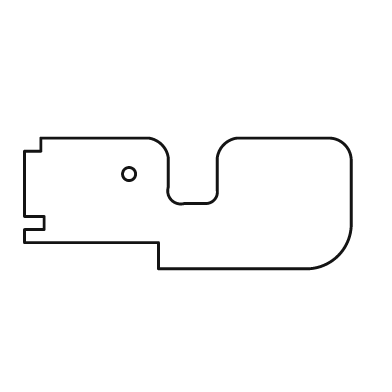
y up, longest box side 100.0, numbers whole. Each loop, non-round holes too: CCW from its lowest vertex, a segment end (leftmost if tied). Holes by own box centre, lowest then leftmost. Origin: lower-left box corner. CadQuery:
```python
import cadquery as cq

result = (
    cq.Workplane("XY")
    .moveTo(41.0, 0.0)
    .lineTo(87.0, 0.0)
    .threePointArc((96.0, 4.0), (100.0, 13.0))
    .lineTo(100.0, 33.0)
    .threePointArc((98.0, 38.0), (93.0, 40.0))
    .lineTo(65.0, 40.0)
    .threePointArc((61.0, 38.0), (59.0, 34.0))
    .lineTo(59.0, 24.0)
    .threePointArc((58.0, 21.0), (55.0, 20.0))
    .lineTo(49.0, 20.0)
    .threePointArc((45.0, 21.0), (44.0, 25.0))
    .lineTo(44.0, 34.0)
    .threePointArc((42.0, 38.0), (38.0, 40.0))
    .lineTo(5.0, 40.0)
    .lineTo(5.0, 36.0)
    .lineTo(0.0, 36.0)
    .lineTo(0.0, 16.0)
    .lineTo(6.0, 16.0)
    .lineTo(6.0, 12.0)
    .lineTo(0.0, 12.0)
    .lineTo(0.0, 8.0)
    .lineTo(41.0, 8.0)
    .close()
    .moveTo(32.0, 29.0)
    .circle(2.0)
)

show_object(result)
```